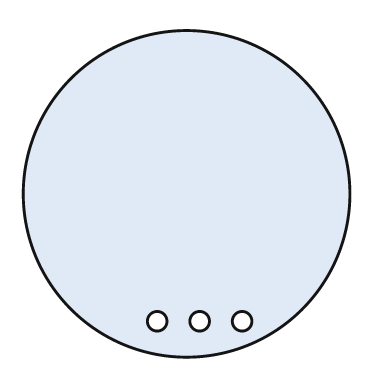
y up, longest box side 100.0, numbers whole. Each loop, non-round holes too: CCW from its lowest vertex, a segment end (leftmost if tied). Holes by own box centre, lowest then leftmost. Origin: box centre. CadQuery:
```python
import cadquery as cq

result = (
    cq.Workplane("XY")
    .moveTo(0.0, 0.0)
    .circle(50.0)
    .moveTo(-9.0, -39.0)
    .circle(3.0)
    .moveTo(4.0, -39.0)
    .circle(3.0)
    .moveTo(17.0, -39.0)
    .circle(3.0)
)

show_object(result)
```